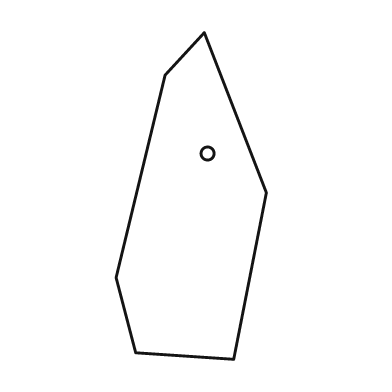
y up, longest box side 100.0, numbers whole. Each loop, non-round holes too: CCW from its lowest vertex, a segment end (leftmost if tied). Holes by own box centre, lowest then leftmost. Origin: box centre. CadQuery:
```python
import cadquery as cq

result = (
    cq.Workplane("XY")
    .moveTo(13.0, -50.0)
    .lineTo(23.0, 1.0)
    .lineTo(4.0, 50.0)
    .lineTo(-8.0, 37.0)
    .lineTo(-23.0, -25.0)
    .lineTo(-17.0, -48.0)
    .close()
    .moveTo(5.0, 13.0)
    .circle(2.0)
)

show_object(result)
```